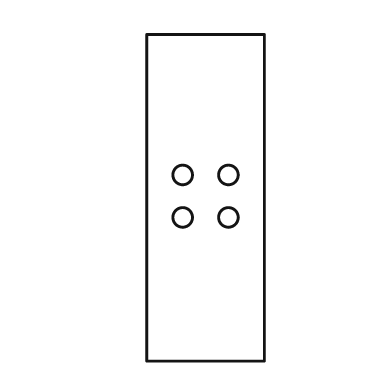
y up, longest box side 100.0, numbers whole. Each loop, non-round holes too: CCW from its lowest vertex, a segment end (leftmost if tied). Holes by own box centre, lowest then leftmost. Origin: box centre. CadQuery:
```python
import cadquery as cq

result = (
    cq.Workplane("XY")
    .moveTo(-18.0, -50.0)
    .lineTo(18.0, -50.0)
    .lineTo(18.0, 50.0)
    .lineTo(-18.0, 50.0)
    .close()
    .moveTo(-7.0, -6.0)
    .circle(3.0)
    .moveTo(7.0, -6.0)
    .circle(3.0)
    .moveTo(-7.0, 7.0)
    .circle(3.0)
    .moveTo(7.0, 7.0)
    .circle(3.0)
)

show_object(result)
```